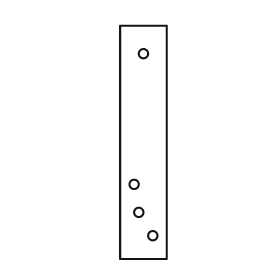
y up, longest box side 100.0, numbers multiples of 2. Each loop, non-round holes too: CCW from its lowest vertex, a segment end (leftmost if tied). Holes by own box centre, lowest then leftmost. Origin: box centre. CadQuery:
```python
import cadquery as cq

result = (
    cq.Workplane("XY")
    .moveTo(-10.0, -50.0)
    .lineTo(10.0, -50.0)
    .lineTo(10.0, 50.0)
    .lineTo(-10.0, 50.0)
    .close()
    .moveTo(4.0, -40.0)
    .circle(2.0)
    .moveTo(-2.0, -30.0)
    .circle(2.0)
    .moveTo(-4.0, -18.0)
    .circle(2.0)
    .moveTo(0.0, 38.0)
    .circle(2.0)
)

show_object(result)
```